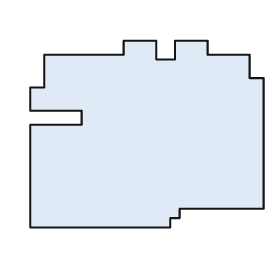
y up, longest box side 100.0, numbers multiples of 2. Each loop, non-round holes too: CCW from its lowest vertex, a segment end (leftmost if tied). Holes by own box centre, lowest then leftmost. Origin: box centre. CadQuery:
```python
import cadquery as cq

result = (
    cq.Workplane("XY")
    .moveTo(-50.0, -40.0)
    .lineTo(10.0, -40.0)
    .lineTo(10.0, -36.0)
    .lineTo(14.0, -36.0)
    .lineTo(14.0, -32.0)
    .lineTo(50.0, -32.0)
    .lineTo(50.0, 24.0)
    .lineTo(44.0, 24.0)
    .lineTo(44.0, 34.0)
    .lineTo(26.0, 34.0)
    .lineTo(26.0, 40.0)
    .lineTo(12.0, 40.0)
    .lineTo(12.0, 32.0)
    .lineTo(4.0, 32.0)
    .lineTo(4.0, 40.0)
    .lineTo(-10.0, 40.0)
    .lineTo(-10.0, 34.0)
    .lineTo(-44.0, 34.0)
    .lineTo(-44.0, 20.0)
    .lineTo(-50.0, 20.0)
    .lineTo(-50.0, 10.0)
    .lineTo(-28.0, 10.0)
    .lineTo(-28.0, 4.0)
    .lineTo(-50.0, 4.0)
    .close()
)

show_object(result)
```